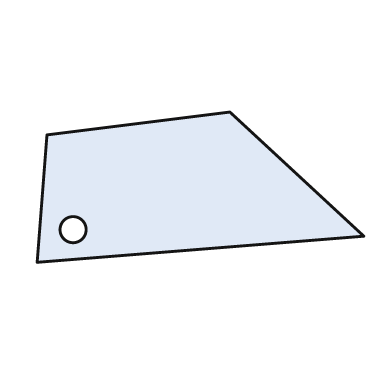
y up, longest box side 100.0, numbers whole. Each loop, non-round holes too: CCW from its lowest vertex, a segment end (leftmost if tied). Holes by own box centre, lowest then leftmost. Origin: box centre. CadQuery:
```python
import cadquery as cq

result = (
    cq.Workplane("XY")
    .moveTo(-50.0, -23.0)
    .lineTo(50.0, -15.0)
    .lineTo(9.0, 23.0)
    .lineTo(-47.0, 16.0)
    .close()
    .moveTo(-39.0, -13.0)
    .circle(4.0)
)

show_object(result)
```